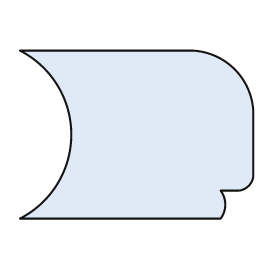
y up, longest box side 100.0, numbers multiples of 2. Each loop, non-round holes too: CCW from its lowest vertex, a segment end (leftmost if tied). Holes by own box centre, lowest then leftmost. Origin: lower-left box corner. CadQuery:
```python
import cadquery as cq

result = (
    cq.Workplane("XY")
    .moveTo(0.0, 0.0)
    .lineTo(86.0, 0.0)
    .threePointArc((88.0, 6.0), (86.0, 12.0))
    .lineTo(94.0, 12.0)
    .threePointArc((98.0, 14.0), (100.0, 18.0))
    .lineTo(100.0, 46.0)
    .threePointArc((92.0, 64.0), (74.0, 72.0))
    .lineTo(0.0, 72.0)
    .threePointArc((22.0, 36.0), (0.0, 0.0))
    .close()
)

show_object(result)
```